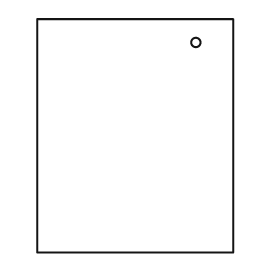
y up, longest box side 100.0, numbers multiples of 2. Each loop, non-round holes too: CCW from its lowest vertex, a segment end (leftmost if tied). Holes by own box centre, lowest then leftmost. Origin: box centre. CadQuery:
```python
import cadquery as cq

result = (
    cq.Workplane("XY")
    .moveTo(-42.0, -50.0)
    .lineTo(42.0, -50.0)
    .lineTo(42.0, 50.0)
    .lineTo(-42.0, 50.0)
    .close()
    .moveTo(26.0, 40.0)
    .circle(2.0)
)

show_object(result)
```